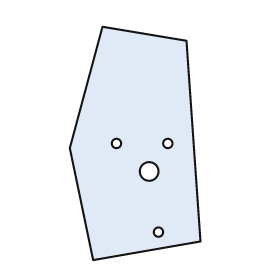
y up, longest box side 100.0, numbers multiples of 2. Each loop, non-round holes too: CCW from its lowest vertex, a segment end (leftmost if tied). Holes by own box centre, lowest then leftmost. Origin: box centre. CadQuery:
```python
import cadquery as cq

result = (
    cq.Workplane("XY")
    .moveTo(-18.0, -50.0)
    .lineTo(28.0, -42.0)
    .lineTo(22.0, 44.0)
    .lineTo(-14.0, 50.0)
    .lineTo(-28.0, -2.0)
    .close()
    .moveTo(10.0, -38.0)
    .circle(2.0)
    .moveTo(6.0, -12.0)
    .circle(4.0)
    .moveTo(-8.0, 0.0)
    .circle(2.0)
    .moveTo(14.0, 0.0)
    .circle(2.0)
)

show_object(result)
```